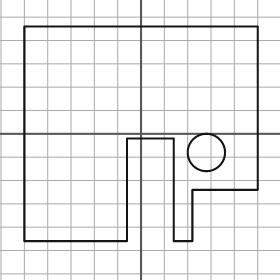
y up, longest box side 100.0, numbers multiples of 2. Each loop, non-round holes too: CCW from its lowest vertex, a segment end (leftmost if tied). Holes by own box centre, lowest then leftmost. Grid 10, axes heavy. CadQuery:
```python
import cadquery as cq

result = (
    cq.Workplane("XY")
    .moveTo(-50.0, -46.0)
    .lineTo(-6.0, -46.0)
    .lineTo(-6.0, -2.0)
    .lineTo(14.0, -2.0)
    .lineTo(14.0, -46.0)
    .lineTo(22.0, -46.0)
    .lineTo(22.0, -24.0)
    .lineTo(50.0, -24.0)
    .lineTo(50.0, 46.0)
    .lineTo(-50.0, 46.0)
    .close()
    .moveTo(28.0, -8.0)
    .circle(8.0)
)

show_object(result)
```